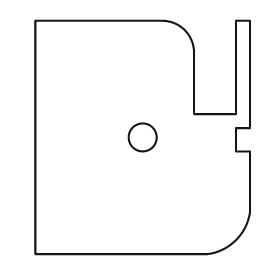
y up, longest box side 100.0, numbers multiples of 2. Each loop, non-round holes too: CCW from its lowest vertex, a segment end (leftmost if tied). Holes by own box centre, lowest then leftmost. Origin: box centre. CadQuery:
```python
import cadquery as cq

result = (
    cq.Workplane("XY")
    .moveTo(-46.0, -50.0)
    .lineTo(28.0, -50.0)
    .threePointArc((40.0, -44.0), (46.0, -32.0))
    .lineTo(46.0, -6.0)
    .lineTo(40.0, -6.0)
    .lineTo(40.0, 4.0)
    .lineTo(46.0, 4.0)
    .lineTo(46.0, 50.0)
    .lineTo(40.0, 50.0)
    .lineTo(40.0, 10.0)
    .lineTo(22.0, 10.0)
    .lineTo(22.0, 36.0)
    .threePointArc((18.0, 46.0), (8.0, 50.0))
    .lineTo(-46.0, 50.0)
    .close()
    .moveTo(0.0, 0.0)
    .circle(6.0)
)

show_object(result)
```